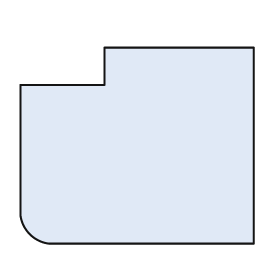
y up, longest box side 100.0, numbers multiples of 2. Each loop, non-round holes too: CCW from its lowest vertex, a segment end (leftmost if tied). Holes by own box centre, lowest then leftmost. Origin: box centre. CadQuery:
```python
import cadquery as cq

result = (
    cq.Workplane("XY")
    .moveTo(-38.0, -42.0)
    .lineTo(50.0, -42.0)
    .lineTo(50.0, 42.0)
    .lineTo(-14.0, 42.0)
    .lineTo(-14.0, 26.0)
    .lineTo(-50.0, 26.0)
    .lineTo(-50.0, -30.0)
    .threePointArc((-46.0, -38.0), (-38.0, -42.0))
    .close()
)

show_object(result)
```